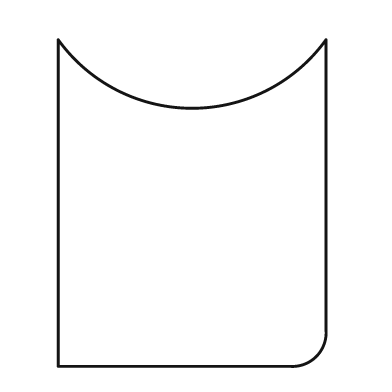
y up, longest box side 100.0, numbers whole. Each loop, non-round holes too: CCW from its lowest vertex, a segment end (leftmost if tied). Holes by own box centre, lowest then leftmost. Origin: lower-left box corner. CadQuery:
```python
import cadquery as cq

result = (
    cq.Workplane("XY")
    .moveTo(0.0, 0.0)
    .lineTo(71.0, 0.0)
    .threePointArc((79.0, 3.0), (82.0, 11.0))
    .lineTo(82.0, 100.0)
    .threePointArc((41.0, 79.0), (0.0, 100.0))
    .close()
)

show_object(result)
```